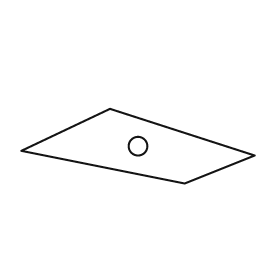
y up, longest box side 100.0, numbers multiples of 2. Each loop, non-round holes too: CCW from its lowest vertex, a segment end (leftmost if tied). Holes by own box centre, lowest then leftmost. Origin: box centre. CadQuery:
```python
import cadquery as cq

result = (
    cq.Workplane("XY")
    .moveTo(20.0, -16.0)
    .lineTo(50.0, -4.0)
    .lineTo(-12.0, 16.0)
    .lineTo(-50.0, -2.0)
    .close()
    .moveTo(0.0, 0.0)
    .circle(4.0)
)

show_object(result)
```